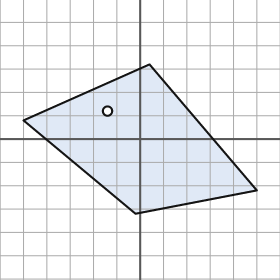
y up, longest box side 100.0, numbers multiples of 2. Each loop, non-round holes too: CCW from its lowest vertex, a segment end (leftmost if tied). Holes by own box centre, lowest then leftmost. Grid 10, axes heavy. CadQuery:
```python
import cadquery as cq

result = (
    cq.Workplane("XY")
    .moveTo(-2.0, -32.0)
    .lineTo(50.0, -22.0)
    .lineTo(4.0, 32.0)
    .lineTo(-50.0, 8.0)
    .close()
    .moveTo(-14.0, 12.0)
    .circle(2.0)
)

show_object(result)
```